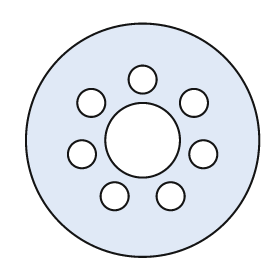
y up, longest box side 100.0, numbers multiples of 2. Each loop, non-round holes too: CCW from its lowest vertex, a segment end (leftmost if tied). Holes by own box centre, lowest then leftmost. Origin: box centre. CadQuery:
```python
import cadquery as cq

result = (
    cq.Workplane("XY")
    .moveTo(0.0, 0.0)
    .circle(50.0)
    .moveTo(-12.0, -24.0)
    .circle(6.0)
    .moveTo(12.0, -24.0)
    .circle(6.0)
    .moveTo(-26.0, -6.0)
    .circle(6.0)
    .moveTo(26.0, -6.0)
    .circle(6.0)
    .moveTo(0.0, 0.0)
    .circle(16.0)
    .moveTo(-22.0, 16.0)
    .circle(6.0)
    .moveTo(22.0, 16.0)
    .circle(6.0)
    .moveTo(0.0, 26.0)
    .circle(6.0)
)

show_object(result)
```